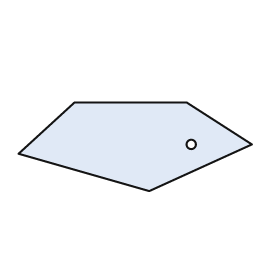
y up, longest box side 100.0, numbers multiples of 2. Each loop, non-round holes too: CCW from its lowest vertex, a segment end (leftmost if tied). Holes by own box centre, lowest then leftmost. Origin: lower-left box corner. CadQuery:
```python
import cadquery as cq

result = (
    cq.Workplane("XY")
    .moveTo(56.0, 0.0)
    .lineTo(100.0, 20.0)
    .lineTo(72.0, 38.0)
    .lineTo(24.0, 38.0)
    .lineTo(0.0, 16.0)
    .close()
    .moveTo(74.0, 20.0)
    .circle(2.0)
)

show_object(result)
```